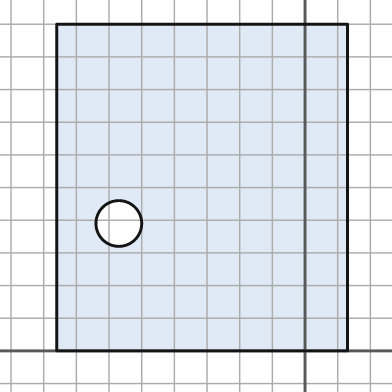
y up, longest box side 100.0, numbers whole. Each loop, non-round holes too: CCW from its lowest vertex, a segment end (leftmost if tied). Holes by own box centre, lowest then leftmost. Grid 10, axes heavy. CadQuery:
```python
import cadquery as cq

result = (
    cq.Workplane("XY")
    .moveTo(-76.0, 0.0)
    .lineTo(13.0, 0.0)
    .lineTo(13.0, 100.0)
    .lineTo(-76.0, 100.0)
    .close()
    .moveTo(-57.0, 39.0)
    .circle(7.0)
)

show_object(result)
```